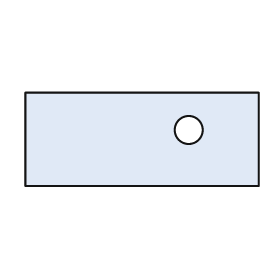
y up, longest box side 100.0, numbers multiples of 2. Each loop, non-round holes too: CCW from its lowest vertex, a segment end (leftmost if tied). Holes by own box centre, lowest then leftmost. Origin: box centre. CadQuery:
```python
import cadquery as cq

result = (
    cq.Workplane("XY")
    .moveTo(-50.0, -20.0)
    .lineTo(50.0, -20.0)
    .lineTo(50.0, 20.0)
    .lineTo(-50.0, 20.0)
    .close()
    .moveTo(20.0, 4.0)
    .circle(6.0)
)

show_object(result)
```